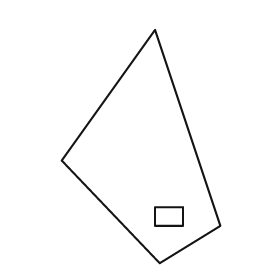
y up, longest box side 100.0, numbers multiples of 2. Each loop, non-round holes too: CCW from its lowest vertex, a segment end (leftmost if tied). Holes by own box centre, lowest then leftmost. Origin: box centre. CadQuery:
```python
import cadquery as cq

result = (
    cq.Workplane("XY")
    .moveTo(8.0, -50.0)
    .lineTo(34.0, -34.0)
    .lineTo(6.0, 50.0)
    .lineTo(-34.0, -6.0)
    .close()
    .moveTo(6.0, -34.0)
    .lineTo(18.0, -34.0)
    .lineTo(18.0, -26.0)
    .lineTo(6.0, -26.0)
    .close()
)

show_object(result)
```